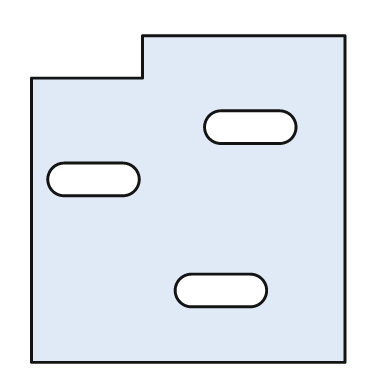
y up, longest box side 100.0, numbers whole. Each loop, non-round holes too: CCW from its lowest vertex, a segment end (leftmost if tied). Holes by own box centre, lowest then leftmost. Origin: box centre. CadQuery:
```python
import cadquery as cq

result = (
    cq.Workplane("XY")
    .moveTo(-48.0, -50.0)
    .lineTo(48.0, -50.0)
    .lineTo(48.0, 50.0)
    .lineTo(-14.0, 50.0)
    .lineTo(-14.0, 37.0)
    .lineTo(-48.0, 37.0)
    .close()
    .moveTo(1.0, -33.0)
    .lineTo(19.0, -33.0)
    .threePointArc((24.0, -28.0), (19.0, -23.0))
    .lineTo(1.0, -23.0)
    .threePointArc((-4.0, -28.0), (1.0, -33.0))
    .close()
    .moveTo(-38.0, 1.0)
    .lineTo(-20.0, 1.0)
    .threePointArc((-15.0, 6.0), (-20.0, 11.0))
    .lineTo(-38.0, 11.0)
    .threePointArc((-43.0, 6.0), (-38.0, 1.0))
    .close()
    .moveTo(10.0, 17.0)
    .lineTo(28.0, 17.0)
    .threePointArc((33.0, 22.0), (28.0, 27.0))
    .lineTo(10.0, 27.0)
    .threePointArc((5.0, 22.0), (10.0, 17.0))
    .close()
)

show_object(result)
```